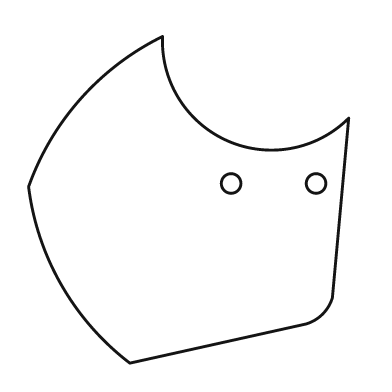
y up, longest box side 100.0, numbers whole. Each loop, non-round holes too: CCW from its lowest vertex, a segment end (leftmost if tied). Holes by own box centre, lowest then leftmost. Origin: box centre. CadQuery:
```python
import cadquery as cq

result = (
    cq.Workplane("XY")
    .moveTo(-18.0, -50.0)
    .lineTo(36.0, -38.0)
    .threePointArc((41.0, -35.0), (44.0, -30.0))
    .lineTo(49.0, 25.0)
    .threePointArc((12.0, 18.0), (-8.0, 50.0))
    .threePointArc((-33.0, 31.0), (-49.0, 4.0))
    .threePointArc((-39.0, -26.0), (-18.0, -50.0))
    .close()
    .moveTo(13.0, 5.0)
    .circle(3.0)
    .moveTo(39.0, 5.0)
    .circle(3.0)
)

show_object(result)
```